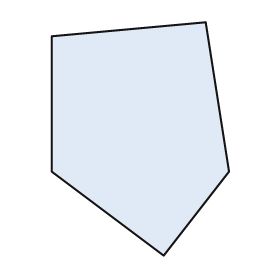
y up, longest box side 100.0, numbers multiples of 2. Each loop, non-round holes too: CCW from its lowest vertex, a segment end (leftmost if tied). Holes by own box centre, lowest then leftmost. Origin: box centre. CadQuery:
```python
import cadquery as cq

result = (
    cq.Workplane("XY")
    .moveTo(10.0, -50.0)
    .lineTo(38.0, -14.0)
    .lineTo(28.0, 50.0)
    .lineTo(-38.0, 44.0)
    .lineTo(-38.0, -14.0)
    .close()
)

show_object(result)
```